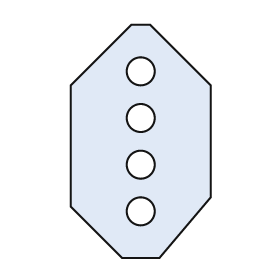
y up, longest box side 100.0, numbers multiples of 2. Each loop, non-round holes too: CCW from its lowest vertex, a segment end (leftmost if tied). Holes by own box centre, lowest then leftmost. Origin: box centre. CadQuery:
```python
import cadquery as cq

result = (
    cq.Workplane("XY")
    .moveTo(-8.0, -50.0)
    .lineTo(8.0, -50.0)
    .lineTo(30.0, -24.0)
    .lineTo(30.0, 24.0)
    .lineTo(4.0, 50.0)
    .lineTo(-4.0, 50.0)
    .lineTo(-30.0, 24.0)
    .lineTo(-30.0, -28.0)
    .close()
    .moveTo(0.0, -30.0)
    .circle(6.0)
    .moveTo(0.0, -10.0)
    .circle(6.0)
    .moveTo(0.0, 10.0)
    .circle(6.0)
    .moveTo(0.0, 30.0)
    .circle(6.0)
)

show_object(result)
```